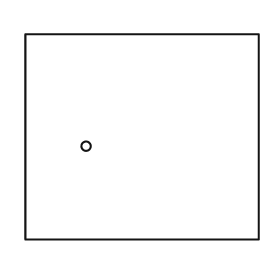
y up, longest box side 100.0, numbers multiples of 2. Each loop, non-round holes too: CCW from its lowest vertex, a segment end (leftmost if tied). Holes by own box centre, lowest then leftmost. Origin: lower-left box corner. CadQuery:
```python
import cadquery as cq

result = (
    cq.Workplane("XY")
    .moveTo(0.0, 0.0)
    .lineTo(100.0, 0.0)
    .lineTo(100.0, 88.0)
    .lineTo(0.0, 88.0)
    .close()
    .moveTo(26.0, 40.0)
    .circle(2.0)
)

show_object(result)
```